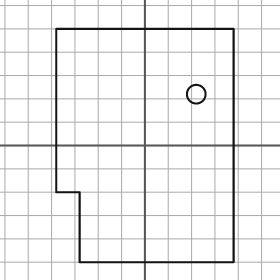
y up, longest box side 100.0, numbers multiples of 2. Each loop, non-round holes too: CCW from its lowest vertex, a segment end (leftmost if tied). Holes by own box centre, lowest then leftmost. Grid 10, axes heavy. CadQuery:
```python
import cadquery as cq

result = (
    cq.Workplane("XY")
    .moveTo(-28.0, -50.0)
    .lineTo(38.0, -50.0)
    .lineTo(38.0, 50.0)
    .lineTo(-38.0, 50.0)
    .lineTo(-38.0, -20.0)
    .lineTo(-28.0, -20.0)
    .close()
    .moveTo(22.0, 22.0)
    .circle(4.0)
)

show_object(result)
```